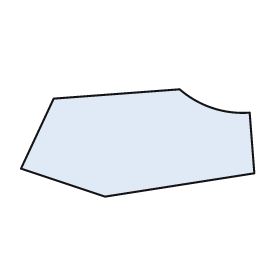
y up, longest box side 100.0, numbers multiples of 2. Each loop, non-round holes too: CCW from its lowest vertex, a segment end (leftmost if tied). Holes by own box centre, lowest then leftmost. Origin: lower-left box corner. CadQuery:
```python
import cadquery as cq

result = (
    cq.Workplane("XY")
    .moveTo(36.0, 0.0)
    .lineTo(100.0, 10.0)
    .lineTo(98.0, 36.0)
    .threePointArc((82.0, 38.0), (68.0, 46.0))
    .lineTo(14.0, 42.0)
    .lineTo(0.0, 12.0)
    .close()
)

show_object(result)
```